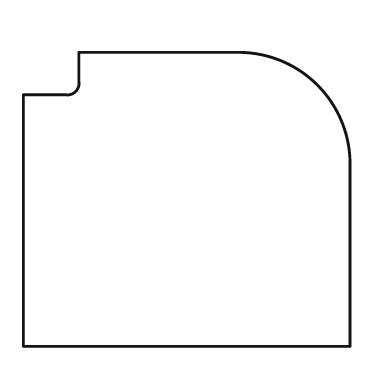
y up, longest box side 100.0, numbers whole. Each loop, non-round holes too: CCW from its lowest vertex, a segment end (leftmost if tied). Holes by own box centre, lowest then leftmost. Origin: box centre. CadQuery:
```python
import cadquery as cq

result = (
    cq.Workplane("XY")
    .moveTo(-50.0, -45.0)
    .lineTo(50.0, -45.0)
    .lineTo(50.0, 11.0)
    .threePointArc((40.0, 35.0), (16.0, 45.0))
    .lineTo(-33.0, 45.0)
    .lineTo(-33.0, 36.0)
    .threePointArc((-34.0, 33.0), (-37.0, 32.0))
    .lineTo(-50.0, 32.0)
    .close()
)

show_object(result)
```